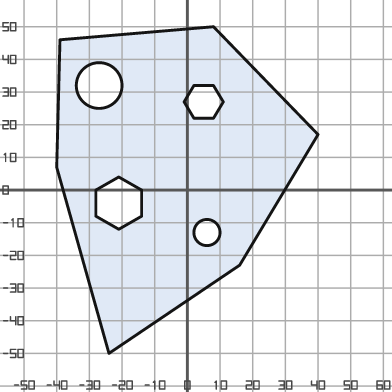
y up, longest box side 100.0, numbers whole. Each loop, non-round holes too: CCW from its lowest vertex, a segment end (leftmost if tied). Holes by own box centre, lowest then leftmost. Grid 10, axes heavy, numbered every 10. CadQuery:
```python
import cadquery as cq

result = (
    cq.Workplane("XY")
    .moveTo(-24.0, -50.0)
    .lineTo(16.0, -23.0)
    .lineTo(40.0, 17.0)
    .lineTo(8.0, 50.0)
    .lineTo(-39.0, 46.0)
    .lineTo(-40.0, 7.0)
    .close()
    .moveTo(6.0, -13.0)
    .circle(4.0)
    .moveTo(-21.0, -12.0)
    .lineTo(-14.0, -8.0)
    .lineTo(-14.0, 0.0)
    .lineTo(-21.0, 4.0)
    .lineTo(-28.0, 0.0)
    .lineTo(-28.0, -8.0)
    .close()
    .moveTo(2.0, 22.0)
    .lineTo(8.0, 22.0)
    .lineTo(11.0, 27.0)
    .lineTo(8.0, 32.0)
    .lineTo(2.0, 32.0)
    .lineTo(-1.0, 27.0)
    .close()
    .moveTo(-27.0, 32.0)
    .circle(7.0)
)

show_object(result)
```